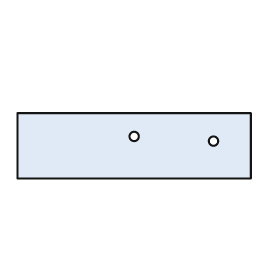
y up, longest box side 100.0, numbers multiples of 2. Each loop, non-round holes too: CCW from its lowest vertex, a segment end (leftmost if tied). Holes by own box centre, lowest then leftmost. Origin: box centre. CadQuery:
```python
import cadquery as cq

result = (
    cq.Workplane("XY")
    .moveTo(-50.0, -14.0)
    .lineTo(50.0, -14.0)
    .lineTo(50.0, 14.0)
    .lineTo(-50.0, 14.0)
    .close()
    .moveTo(34.0, 2.0)
    .circle(2.0)
    .moveTo(0.0, 4.0)
    .circle(2.0)
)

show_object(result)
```